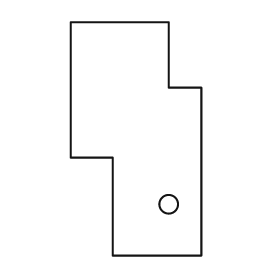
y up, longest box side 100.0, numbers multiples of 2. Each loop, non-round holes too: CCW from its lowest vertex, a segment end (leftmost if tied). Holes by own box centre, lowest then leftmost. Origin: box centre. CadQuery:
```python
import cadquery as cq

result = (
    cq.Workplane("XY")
    .moveTo(-10.0, -50.0)
    .lineTo(28.0, -50.0)
    .lineTo(28.0, 22.0)
    .lineTo(14.0, 22.0)
    .lineTo(14.0, 50.0)
    .lineTo(-28.0, 50.0)
    .lineTo(-28.0, -8.0)
    .lineTo(-10.0, -8.0)
    .close()
    .moveTo(14.0, -28.0)
    .circle(4.0)
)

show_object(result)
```